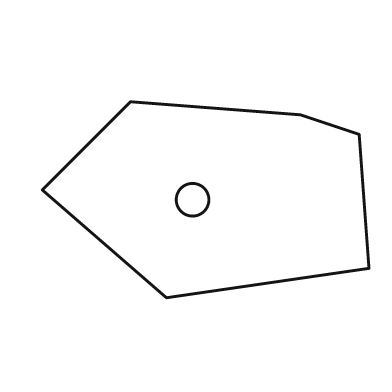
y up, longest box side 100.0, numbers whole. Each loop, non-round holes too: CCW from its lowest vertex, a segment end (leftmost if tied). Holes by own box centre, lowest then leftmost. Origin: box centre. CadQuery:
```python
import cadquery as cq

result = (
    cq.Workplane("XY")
    .moveTo(-12.0, -30.0)
    .lineTo(50.0, -21.0)
    .lineTo(47.0, 20.0)
    .lineTo(29.0, 26.0)
    .lineTo(-23.0, 30.0)
    .lineTo(-50.0, 3.0)
    .close()
    .moveTo(-4.0, 0.0)
    .circle(5.0)
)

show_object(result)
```